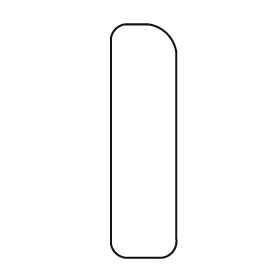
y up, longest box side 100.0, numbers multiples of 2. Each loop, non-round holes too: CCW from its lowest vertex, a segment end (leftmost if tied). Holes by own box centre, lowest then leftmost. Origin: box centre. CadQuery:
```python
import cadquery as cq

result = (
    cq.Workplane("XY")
    .moveTo(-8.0, -50.0)
    .lineTo(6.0, -50.0)
    .threePointArc((12.0, -48.0), (14.0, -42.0))
    .lineTo(14.0, 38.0)
    .threePointArc((10.0, 46.0), (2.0, 50.0))
    .lineTo(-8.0, 50.0)
    .threePointArc((-12.0, 48.0), (-14.0, 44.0))
    .lineTo(-14.0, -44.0)
    .threePointArc((-12.0, -48.0), (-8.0, -50.0))
    .close()
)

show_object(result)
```